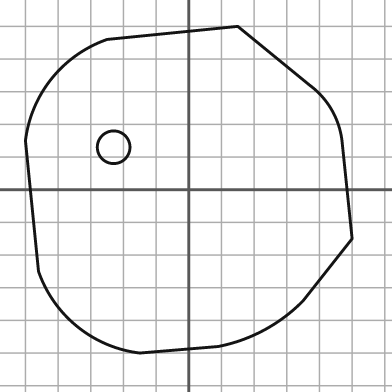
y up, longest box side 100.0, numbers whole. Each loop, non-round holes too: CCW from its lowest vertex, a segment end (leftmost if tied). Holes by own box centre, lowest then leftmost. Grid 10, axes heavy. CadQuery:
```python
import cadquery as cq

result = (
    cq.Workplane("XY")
    .moveTo(-15.0, -50.0)
    .lineTo(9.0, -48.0)
    .threePointArc((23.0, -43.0), (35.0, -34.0))
    .lineTo(50.0, -15.0)
    .lineTo(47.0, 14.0)
    .threePointArc((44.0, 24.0), (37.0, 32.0))
    .lineTo(15.0, 50.0)
    .lineTo(-25.0, 46.0)
    .threePointArc((-42.0, 34.0), (-50.0, 15.0))
    .lineTo(-46.0, -25.0)
    .threePointArc((-34.0, -42.0), (-15.0, -50.0))
    .close()
    .moveTo(-23.0, 13.0)
    .circle(5.0)
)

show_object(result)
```